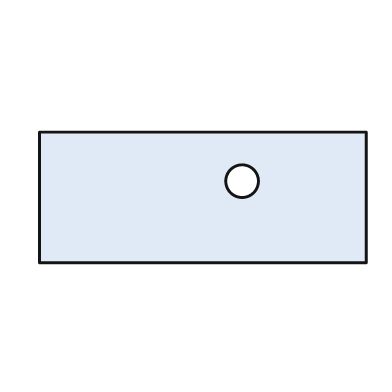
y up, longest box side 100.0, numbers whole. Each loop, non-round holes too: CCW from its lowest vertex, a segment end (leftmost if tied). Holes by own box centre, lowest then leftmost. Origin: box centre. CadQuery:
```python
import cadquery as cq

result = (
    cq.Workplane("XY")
    .moveTo(-50.0, -20.0)
    .lineTo(50.0, -20.0)
    .lineTo(50.0, 20.0)
    .lineTo(-50.0, 20.0)
    .close()
    .moveTo(12.0, 5.0)
    .circle(5.0)
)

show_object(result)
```